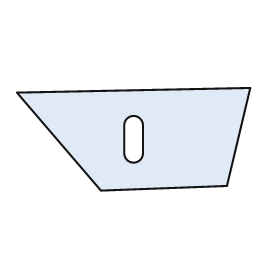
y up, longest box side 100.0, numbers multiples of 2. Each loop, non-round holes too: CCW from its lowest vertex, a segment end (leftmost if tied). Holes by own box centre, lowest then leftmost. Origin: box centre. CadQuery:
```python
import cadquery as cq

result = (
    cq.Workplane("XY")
    .moveTo(-14.0, -22.0)
    .lineTo(40.0, -20.0)
    .lineTo(50.0, 22.0)
    .lineTo(-50.0, 20.0)
    .close()
    .moveTo(-4.0, -6.0)
    .threePointArc((0.0, -10.0), (4.0, -6.0))
    .lineTo(4.0, 6.0)
    .threePointArc((0.0, 10.0), (-4.0, 6.0))
    .close()
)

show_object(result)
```